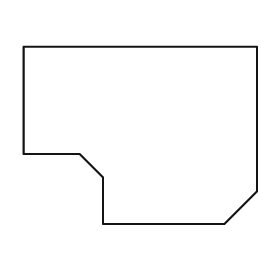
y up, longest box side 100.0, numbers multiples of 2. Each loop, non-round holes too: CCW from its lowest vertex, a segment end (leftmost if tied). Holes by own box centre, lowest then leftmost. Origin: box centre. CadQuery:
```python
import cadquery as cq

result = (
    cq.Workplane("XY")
    .moveTo(-16.0, -38.0)
    .lineTo(36.0, -38.0)
    .lineTo(50.0, -24.0)
    .lineTo(50.0, 38.0)
    .lineTo(-50.0, 38.0)
    .lineTo(-50.0, -8.0)
    .lineTo(-26.0, -8.0)
    .lineTo(-16.0, -18.0)
    .close()
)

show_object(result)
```